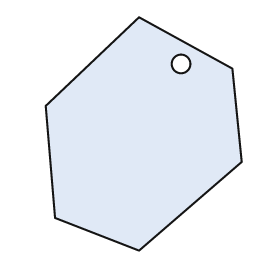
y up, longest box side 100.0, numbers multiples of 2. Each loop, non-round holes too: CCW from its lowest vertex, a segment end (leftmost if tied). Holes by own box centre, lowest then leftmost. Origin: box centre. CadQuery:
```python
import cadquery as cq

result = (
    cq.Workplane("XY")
    .moveTo(-2.0, -50.0)
    .lineTo(42.0, -12.0)
    .lineTo(38.0, 28.0)
    .lineTo(-2.0, 50.0)
    .lineTo(-42.0, 12.0)
    .lineTo(-38.0, -36.0)
    .close()
    .moveTo(16.0, 30.0)
    .circle(4.0)
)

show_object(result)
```